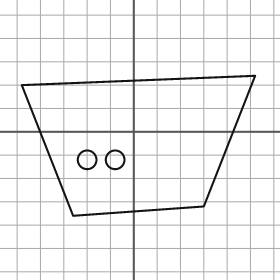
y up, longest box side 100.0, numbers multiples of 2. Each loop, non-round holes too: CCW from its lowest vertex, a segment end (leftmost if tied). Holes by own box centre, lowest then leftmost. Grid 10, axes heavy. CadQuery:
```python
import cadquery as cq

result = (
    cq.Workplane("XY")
    .moveTo(-26.0, -36.0)
    .lineTo(30.0, -32.0)
    .lineTo(52.0, 24.0)
    .lineTo(-48.0, 20.0)
    .close()
    .moveTo(-20.0, -12.0)
    .circle(4.0)
    .moveTo(-8.0, -12.0)
    .circle(4.0)
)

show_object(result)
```